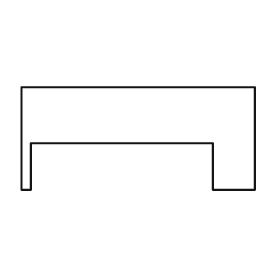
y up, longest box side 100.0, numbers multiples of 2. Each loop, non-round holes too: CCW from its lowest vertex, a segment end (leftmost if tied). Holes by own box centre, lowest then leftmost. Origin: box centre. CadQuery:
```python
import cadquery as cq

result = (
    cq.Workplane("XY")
    .moveTo(-50.0, -22.0)
    .lineTo(-46.0, -22.0)
    .lineTo(-46.0, -2.0)
    .lineTo(32.0, -2.0)
    .lineTo(32.0, -22.0)
    .lineTo(50.0, -22.0)
    .lineTo(50.0, 22.0)
    .lineTo(-50.0, 22.0)
    .close()
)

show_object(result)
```